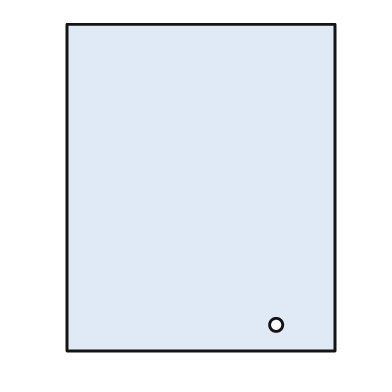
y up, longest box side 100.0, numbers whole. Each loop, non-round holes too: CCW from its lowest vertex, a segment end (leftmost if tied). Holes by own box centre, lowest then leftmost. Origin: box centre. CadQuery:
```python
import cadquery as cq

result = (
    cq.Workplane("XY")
    .moveTo(-41.0, -50.0)
    .lineTo(41.0, -50.0)
    .lineTo(41.0, 50.0)
    .lineTo(-41.0, 50.0)
    .close()
    .moveTo(23.0, -42.0)
    .circle(2.0)
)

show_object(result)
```